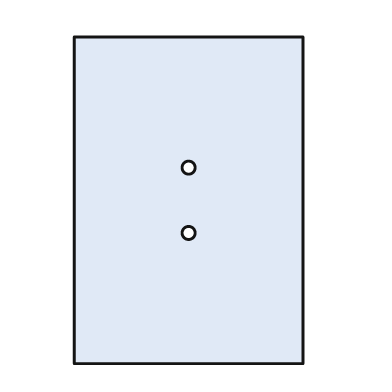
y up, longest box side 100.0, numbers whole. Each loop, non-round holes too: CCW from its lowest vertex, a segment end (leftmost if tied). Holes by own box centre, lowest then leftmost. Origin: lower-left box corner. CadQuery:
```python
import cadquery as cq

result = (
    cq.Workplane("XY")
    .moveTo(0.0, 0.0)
    .lineTo(70.0, 0.0)
    .lineTo(70.0, 100.0)
    .lineTo(0.0, 100.0)
    .close()
    .moveTo(35.0, 40.0)
    .circle(2.0)
    .moveTo(35.0, 60.0)
    .circle(2.0)
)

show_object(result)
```